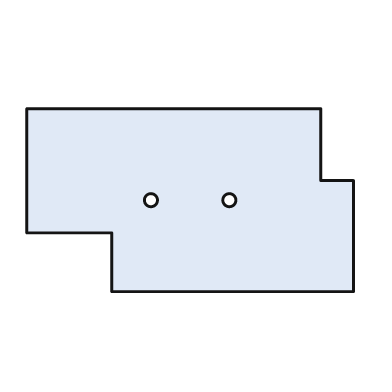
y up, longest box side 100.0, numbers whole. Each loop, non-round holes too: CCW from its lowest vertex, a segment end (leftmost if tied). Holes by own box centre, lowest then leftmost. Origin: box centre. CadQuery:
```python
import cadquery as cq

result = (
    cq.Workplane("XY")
    .moveTo(-24.0, -28.0)
    .lineTo(50.0, -28.0)
    .lineTo(50.0, 6.0)
    .lineTo(40.0, 6.0)
    .lineTo(40.0, 28.0)
    .lineTo(-50.0, 28.0)
    .lineTo(-50.0, -10.0)
    .lineTo(-24.0, -10.0)
    .close()
    .moveTo(-12.0, 0.0)
    .circle(2.0)
    .moveTo(12.0, 0.0)
    .circle(2.0)
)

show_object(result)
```